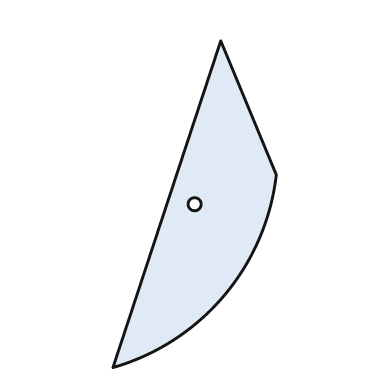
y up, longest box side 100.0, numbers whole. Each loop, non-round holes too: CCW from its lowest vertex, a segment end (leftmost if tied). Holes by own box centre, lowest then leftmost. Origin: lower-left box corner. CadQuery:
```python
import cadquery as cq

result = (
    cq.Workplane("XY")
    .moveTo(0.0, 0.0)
    .threePointArc((34.0, 22.0), (50.0, 59.0))
    .lineTo(33.0, 100.0)
    .close()
    .moveTo(25.0, 50.0)
    .circle(2.0)
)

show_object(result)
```